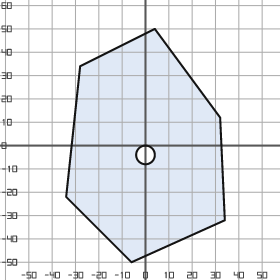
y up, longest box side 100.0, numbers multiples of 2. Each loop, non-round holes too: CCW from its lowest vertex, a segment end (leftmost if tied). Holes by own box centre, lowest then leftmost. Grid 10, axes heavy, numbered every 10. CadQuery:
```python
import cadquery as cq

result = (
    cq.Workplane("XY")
    .moveTo(-6.0, -50.0)
    .lineTo(34.0, -32.0)
    .lineTo(32.0, 12.0)
    .lineTo(4.0, 50.0)
    .lineTo(-28.0, 34.0)
    .lineTo(-34.0, -22.0)
    .close()
    .moveTo(0.0, -4.0)
    .circle(4.0)
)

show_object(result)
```